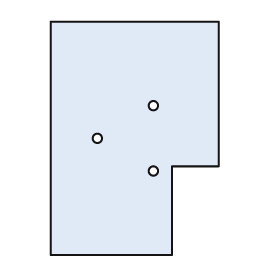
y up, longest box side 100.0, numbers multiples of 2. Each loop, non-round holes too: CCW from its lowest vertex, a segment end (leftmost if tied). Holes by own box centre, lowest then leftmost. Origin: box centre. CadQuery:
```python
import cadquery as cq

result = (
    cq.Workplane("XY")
    .moveTo(-36.0, -50.0)
    .lineTo(16.0, -50.0)
    .lineTo(16.0, -12.0)
    .lineTo(36.0, -12.0)
    .lineTo(36.0, 50.0)
    .lineTo(-36.0, 50.0)
    .close()
    .moveTo(8.0, -14.0)
    .circle(2.0)
    .moveTo(-16.0, 0.0)
    .circle(2.0)
    .moveTo(8.0, 14.0)
    .circle(2.0)
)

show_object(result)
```